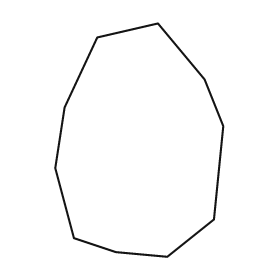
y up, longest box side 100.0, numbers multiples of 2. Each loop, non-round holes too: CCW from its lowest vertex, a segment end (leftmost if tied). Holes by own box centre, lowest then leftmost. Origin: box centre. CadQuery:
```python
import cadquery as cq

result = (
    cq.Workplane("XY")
    .moveTo(12.0, -50.0)
    .lineTo(32.0, -34.0)
    .lineTo(36.0, 6.0)
    .lineTo(28.0, 26.0)
    .lineTo(8.0, 50.0)
    .lineTo(-18.0, 44.0)
    .lineTo(-32.0, 14.0)
    .lineTo(-36.0, -12.0)
    .lineTo(-28.0, -42.0)
    .lineTo(-10.0, -48.0)
    .close()
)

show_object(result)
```